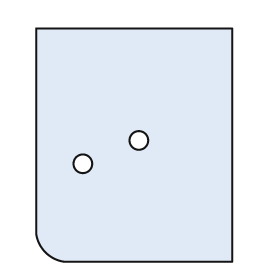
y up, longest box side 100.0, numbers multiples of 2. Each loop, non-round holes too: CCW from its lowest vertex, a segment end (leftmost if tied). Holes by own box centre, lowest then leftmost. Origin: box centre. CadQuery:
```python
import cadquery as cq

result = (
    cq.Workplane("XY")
    .moveTo(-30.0, -50.0)
    .lineTo(42.0, -50.0)
    .lineTo(42.0, 50.0)
    .lineTo(-42.0, 50.0)
    .lineTo(-42.0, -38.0)
    .threePointArc((-38.0, -46.0), (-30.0, -50.0))
    .close()
    .moveTo(-22.0, -8.0)
    .circle(4.0)
    .moveTo(2.0, 2.0)
    .circle(4.0)
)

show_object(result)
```